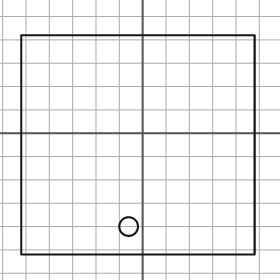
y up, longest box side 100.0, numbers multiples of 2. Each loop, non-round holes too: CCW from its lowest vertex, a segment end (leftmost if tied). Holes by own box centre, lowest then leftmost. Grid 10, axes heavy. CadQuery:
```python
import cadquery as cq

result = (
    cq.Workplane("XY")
    .moveTo(-52.0, -52.0)
    .lineTo(48.0, -52.0)
    .lineTo(48.0, 42.0)
    .lineTo(-52.0, 42.0)
    .close()
    .moveTo(-6.0, -40.0)
    .circle(4.0)
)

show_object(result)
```